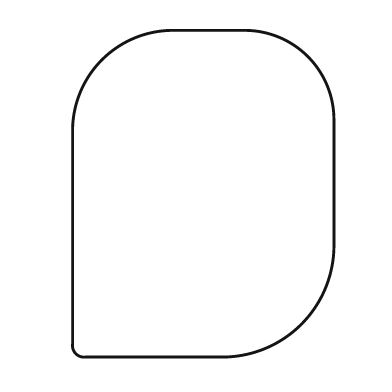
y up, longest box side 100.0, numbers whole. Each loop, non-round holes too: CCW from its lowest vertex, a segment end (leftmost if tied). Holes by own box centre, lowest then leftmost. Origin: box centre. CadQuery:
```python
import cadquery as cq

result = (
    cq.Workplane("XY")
    .moveTo(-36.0, -50.0)
    .lineTo(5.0, -50.0)
    .threePointArc((30.0, -40.0), (40.0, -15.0))
    .lineTo(40.0, 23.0)
    .threePointArc((32.0, 42.0), (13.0, 50.0))
    .lineTo(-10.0, 50.0)
    .threePointArc((-31.0, 41.0), (-40.0, 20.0))
    .lineTo(-40.0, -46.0)
    .threePointArc((-39.0, -49.0), (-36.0, -50.0))
    .close()
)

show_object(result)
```